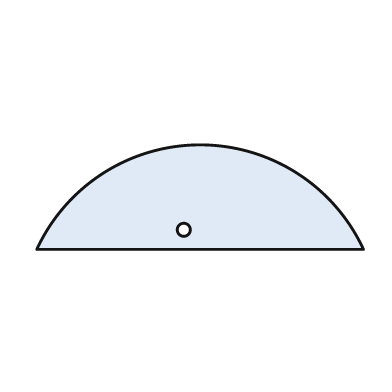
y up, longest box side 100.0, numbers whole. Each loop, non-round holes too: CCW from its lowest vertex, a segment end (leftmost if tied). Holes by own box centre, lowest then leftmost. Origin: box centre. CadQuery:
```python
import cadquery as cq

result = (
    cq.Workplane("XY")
    .moveTo(-50.0, -16.0)
    .lineTo(50.0, -16.0)
    .threePointArc((0.0, 16.0), (-50.0, -16.0))
    .close()
    .moveTo(-5.0, -10.0)
    .circle(2.0)
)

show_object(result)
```